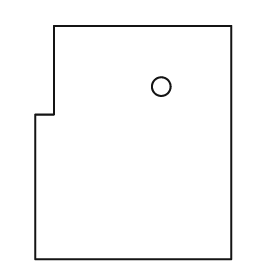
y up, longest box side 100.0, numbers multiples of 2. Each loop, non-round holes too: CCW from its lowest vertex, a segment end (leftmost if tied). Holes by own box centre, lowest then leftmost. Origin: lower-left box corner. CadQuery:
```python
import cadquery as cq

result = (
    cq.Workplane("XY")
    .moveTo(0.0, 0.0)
    .lineTo(84.0, 0.0)
    .lineTo(84.0, 100.0)
    .lineTo(8.0, 100.0)
    .lineTo(8.0, 62.0)
    .lineTo(0.0, 62.0)
    .close()
    .moveTo(54.0, 74.0)
    .circle(4.0)
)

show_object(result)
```